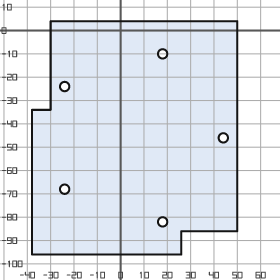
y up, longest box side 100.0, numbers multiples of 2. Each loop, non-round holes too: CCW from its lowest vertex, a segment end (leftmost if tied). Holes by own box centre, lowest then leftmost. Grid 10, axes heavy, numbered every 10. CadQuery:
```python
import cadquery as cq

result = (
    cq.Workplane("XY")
    .moveTo(-38.0, -96.0)
    .lineTo(26.0, -96.0)
    .lineTo(26.0, -86.0)
    .lineTo(50.0, -86.0)
    .lineTo(50.0, 4.0)
    .lineTo(-30.0, 4.0)
    .lineTo(-30.0, -34.0)
    .lineTo(-38.0, -34.0)
    .close()
    .moveTo(18.0, -82.0)
    .circle(2.0)
    .moveTo(-24.0, -68.0)
    .circle(2.0)
    .moveTo(44.0, -46.0)
    .circle(2.0)
    .moveTo(-24.0, -24.0)
    .circle(2.0)
    .moveTo(18.0, -10.0)
    .circle(2.0)
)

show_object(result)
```